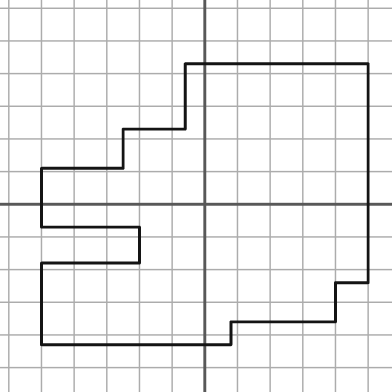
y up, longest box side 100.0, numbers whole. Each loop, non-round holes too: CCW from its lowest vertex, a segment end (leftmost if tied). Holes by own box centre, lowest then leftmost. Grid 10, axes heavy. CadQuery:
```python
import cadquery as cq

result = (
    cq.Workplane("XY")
    .moveTo(-50.0, -43.0)
    .lineTo(8.0, -43.0)
    .lineTo(8.0, -36.0)
    .lineTo(40.0, -36.0)
    .lineTo(40.0, -24.0)
    .lineTo(50.0, -24.0)
    .lineTo(50.0, 43.0)
    .lineTo(-6.0, 43.0)
    .lineTo(-6.0, 23.0)
    .lineTo(-25.0, 23.0)
    .lineTo(-25.0, 11.0)
    .lineTo(-50.0, 11.0)
    .lineTo(-50.0, -7.0)
    .lineTo(-20.0, -7.0)
    .lineTo(-20.0, -18.0)
    .lineTo(-50.0, -18.0)
    .close()
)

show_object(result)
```